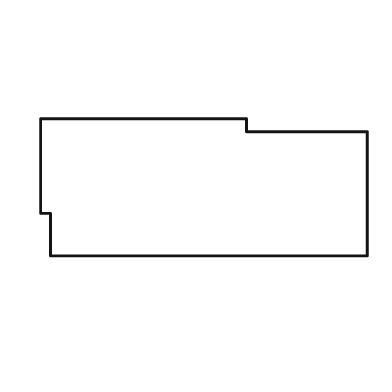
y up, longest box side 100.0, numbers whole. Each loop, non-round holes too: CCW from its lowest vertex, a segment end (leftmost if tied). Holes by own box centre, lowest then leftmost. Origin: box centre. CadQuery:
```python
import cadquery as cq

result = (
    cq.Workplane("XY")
    .moveTo(-47.0, -21.0)
    .lineTo(50.0, -21.0)
    .lineTo(50.0, 17.0)
    .lineTo(13.0, 17.0)
    .lineTo(13.0, 21.0)
    .lineTo(-50.0, 21.0)
    .lineTo(-50.0, -8.0)
    .lineTo(-47.0, -8.0)
    .close()
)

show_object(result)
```